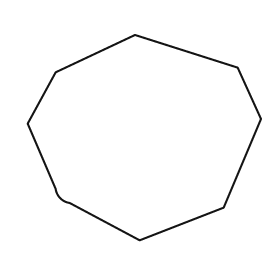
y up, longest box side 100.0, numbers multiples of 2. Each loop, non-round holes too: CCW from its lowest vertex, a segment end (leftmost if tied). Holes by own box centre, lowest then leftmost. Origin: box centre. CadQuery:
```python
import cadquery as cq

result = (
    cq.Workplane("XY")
    .moveTo(-2.0, -44.0)
    .lineTo(34.0, -30.0)
    .lineTo(50.0, 8.0)
    .lineTo(40.0, 30.0)
    .lineTo(-4.0, 44.0)
    .lineTo(-38.0, 28.0)
    .lineTo(-50.0, 6.0)
    .lineTo(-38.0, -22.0)
    .threePointArc((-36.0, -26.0), (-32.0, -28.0))
    .close()
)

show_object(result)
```